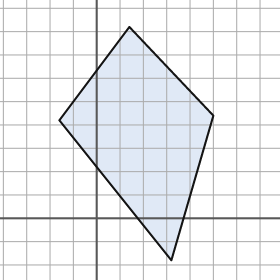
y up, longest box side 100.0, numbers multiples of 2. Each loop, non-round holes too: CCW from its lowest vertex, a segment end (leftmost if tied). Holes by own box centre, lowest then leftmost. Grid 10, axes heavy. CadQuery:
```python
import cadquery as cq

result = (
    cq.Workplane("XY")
    .moveTo(32.0, -18.0)
    .lineTo(50.0, 44.0)
    .lineTo(14.0, 82.0)
    .lineTo(-16.0, 42.0)
    .close()
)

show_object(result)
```